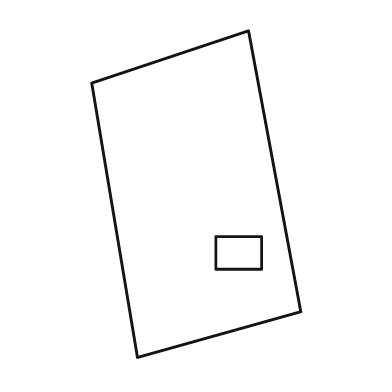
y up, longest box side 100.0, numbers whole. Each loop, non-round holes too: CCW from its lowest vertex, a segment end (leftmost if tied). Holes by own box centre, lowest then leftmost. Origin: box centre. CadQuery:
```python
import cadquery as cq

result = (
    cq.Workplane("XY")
    .moveTo(-18.0, -50.0)
    .lineTo(32.0, -36.0)
    .lineTo(16.0, 50.0)
    .lineTo(-32.0, 34.0)
    .close()
    .moveTo(6.0, -23.0)
    .lineTo(20.0, -23.0)
    .lineTo(20.0, -13.0)
    .lineTo(6.0, -13.0)
    .close()
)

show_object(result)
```